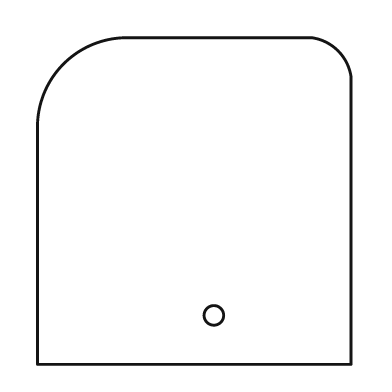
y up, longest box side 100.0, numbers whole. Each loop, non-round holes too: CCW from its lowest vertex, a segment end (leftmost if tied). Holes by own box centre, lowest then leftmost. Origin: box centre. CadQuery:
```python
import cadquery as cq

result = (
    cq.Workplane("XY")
    .moveTo(-48.0, -50.0)
    .lineTo(48.0, -50.0)
    .lineTo(48.0, 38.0)
    .threePointArc((44.0, 46.0), (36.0, 50.0))
    .lineTo(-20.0, 50.0)
    .threePointArc((-40.0, 42.0), (-48.0, 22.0))
    .close()
    .moveTo(6.0, -35.0)
    .circle(3.0)
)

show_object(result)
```